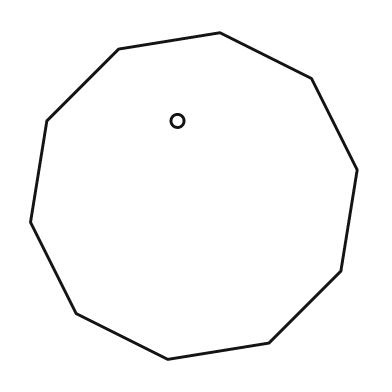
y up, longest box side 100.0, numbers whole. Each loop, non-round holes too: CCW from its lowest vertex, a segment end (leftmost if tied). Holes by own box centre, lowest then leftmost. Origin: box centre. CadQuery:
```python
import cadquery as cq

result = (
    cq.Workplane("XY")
    .moveTo(-8.0, -50.0)
    .lineTo(23.0, -45.0)
    .lineTo(45.0, -23.0)
    .lineTo(50.0, 8.0)
    .lineTo(36.0, 36.0)
    .lineTo(8.0, 50.0)
    .lineTo(-23.0, 45.0)
    .lineTo(-45.0, 23.0)
    .lineTo(-50.0, -8.0)
    .lineTo(-36.0, -36.0)
    .close()
    .moveTo(-5.0, 23.0)
    .circle(2.0)
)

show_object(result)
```